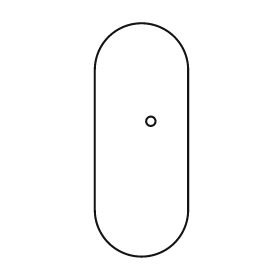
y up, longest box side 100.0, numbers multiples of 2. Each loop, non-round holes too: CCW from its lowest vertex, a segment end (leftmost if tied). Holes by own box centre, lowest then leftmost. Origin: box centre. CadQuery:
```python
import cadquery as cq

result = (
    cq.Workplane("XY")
    .moveTo(-20.0, -30.0)
    .threePointArc((0.0, -50.0), (20.0, -30.0))
    .lineTo(20.0, 30.0)
    .threePointArc((0.0, 50.0), (-20.0, 30.0))
    .close()
    .moveTo(4.0, 8.0)
    .circle(2.0)
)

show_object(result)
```